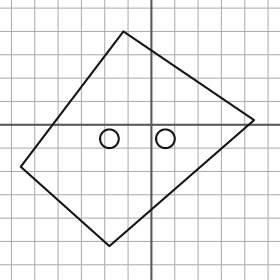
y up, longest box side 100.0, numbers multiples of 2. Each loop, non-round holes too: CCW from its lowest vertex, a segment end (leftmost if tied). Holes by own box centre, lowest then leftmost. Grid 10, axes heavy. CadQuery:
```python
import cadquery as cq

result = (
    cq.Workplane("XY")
    .moveTo(-18.0, -52.0)
    .lineTo(44.0, 2.0)
    .lineTo(-12.0, 40.0)
    .lineTo(-56.0, -18.0)
    .close()
    .moveTo(-18.0, -6.0)
    .circle(4.0)
    .moveTo(6.0, -6.0)
    .circle(4.0)
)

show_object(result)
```